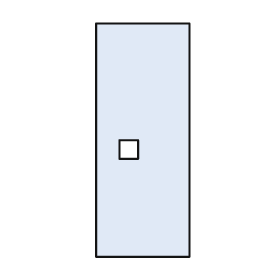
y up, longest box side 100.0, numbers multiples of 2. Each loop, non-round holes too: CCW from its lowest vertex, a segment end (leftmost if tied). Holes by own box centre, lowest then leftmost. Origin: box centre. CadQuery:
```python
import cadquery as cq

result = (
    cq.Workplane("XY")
    .moveTo(-20.0, -50.0)
    .lineTo(20.0, -50.0)
    .lineTo(20.0, 50.0)
    .lineTo(-20.0, 50.0)
    .close()
    .moveTo(-10.0, -8.0)
    .lineTo(-2.0, -8.0)
    .lineTo(-2.0, 0.0)
    .lineTo(-10.0, 0.0)
    .close()
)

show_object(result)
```